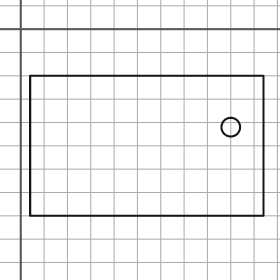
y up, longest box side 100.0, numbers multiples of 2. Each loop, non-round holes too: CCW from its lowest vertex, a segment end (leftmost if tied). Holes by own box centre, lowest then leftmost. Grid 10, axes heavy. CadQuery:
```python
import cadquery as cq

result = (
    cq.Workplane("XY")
    .moveTo(4.0, -80.0)
    .lineTo(104.0, -80.0)
    .lineTo(104.0, -20.0)
    .lineTo(4.0, -20.0)
    .close()
    .moveTo(90.0, -42.0)
    .circle(4.0)
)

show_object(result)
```